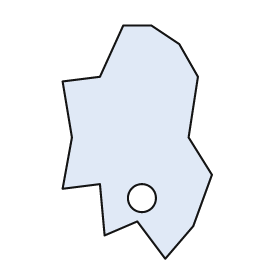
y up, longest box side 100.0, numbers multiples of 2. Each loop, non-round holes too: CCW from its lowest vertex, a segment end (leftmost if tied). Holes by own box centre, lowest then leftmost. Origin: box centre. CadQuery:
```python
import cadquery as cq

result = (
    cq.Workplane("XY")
    .moveTo(12.0, -50.0)
    .lineTo(24.0, -36.0)
    .lineTo(32.0, -14.0)
    .lineTo(22.0, 2.0)
    .lineTo(26.0, 28.0)
    .lineTo(18.0, 42.0)
    .lineTo(6.0, 50.0)
    .lineTo(-6.0, 50.0)
    .lineTo(-16.0, 28.0)
    .lineTo(-32.0, 26.0)
    .lineTo(-28.0, 2.0)
    .lineTo(-32.0, -20.0)
    .lineTo(-16.0, -18.0)
    .lineTo(-14.0, -40.0)
    .lineTo(0.0, -34.0)
    .close()
    .moveTo(2.0, -24.0)
    .circle(6.0)
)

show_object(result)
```